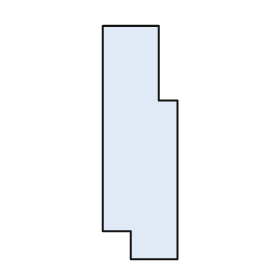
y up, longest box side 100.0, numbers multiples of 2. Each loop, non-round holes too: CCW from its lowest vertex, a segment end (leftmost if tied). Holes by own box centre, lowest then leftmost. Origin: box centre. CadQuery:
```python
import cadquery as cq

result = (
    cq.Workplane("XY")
    .moveTo(-4.0, -50.0)
    .lineTo(16.0, -50.0)
    .lineTo(16.0, 18.0)
    .lineTo(8.0, 18.0)
    .lineTo(8.0, 50.0)
    .lineTo(-16.0, 50.0)
    .lineTo(-16.0, -38.0)
    .lineTo(-4.0, -38.0)
    .close()
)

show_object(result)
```